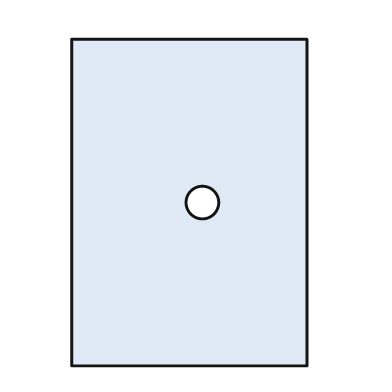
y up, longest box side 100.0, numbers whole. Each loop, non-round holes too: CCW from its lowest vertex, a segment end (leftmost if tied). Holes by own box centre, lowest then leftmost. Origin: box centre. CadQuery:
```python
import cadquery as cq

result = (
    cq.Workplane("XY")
    .moveTo(-36.0, -50.0)
    .lineTo(36.0, -50.0)
    .lineTo(36.0, 50.0)
    .lineTo(-36.0, 50.0)
    .close()
    .moveTo(4.0, 0.0)
    .circle(5.0)
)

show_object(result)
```